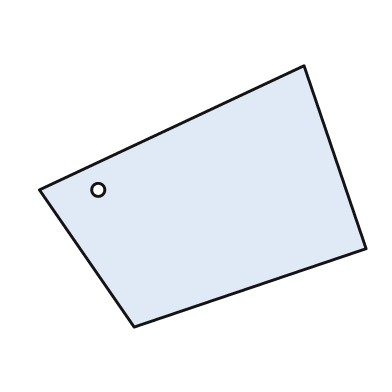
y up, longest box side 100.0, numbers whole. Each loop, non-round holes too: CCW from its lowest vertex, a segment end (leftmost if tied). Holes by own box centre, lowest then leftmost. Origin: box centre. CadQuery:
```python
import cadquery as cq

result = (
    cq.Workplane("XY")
    .moveTo(-21.0, -40.0)
    .lineTo(50.0, -16.0)
    .lineTo(31.0, 40.0)
    .lineTo(-50.0, 2.0)
    .close()
    .moveTo(-32.0, 2.0)
    .circle(2.0)
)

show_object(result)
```